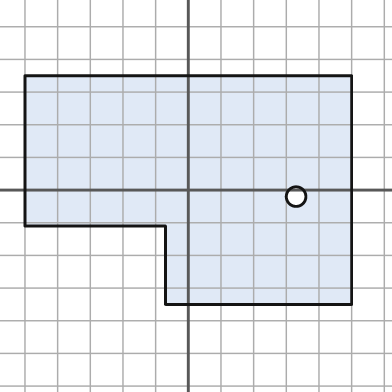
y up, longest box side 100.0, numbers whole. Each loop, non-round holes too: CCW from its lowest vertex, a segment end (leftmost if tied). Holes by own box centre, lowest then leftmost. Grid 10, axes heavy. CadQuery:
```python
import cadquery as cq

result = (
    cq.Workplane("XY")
    .moveTo(-7.0, -35.0)
    .lineTo(50.0, -35.0)
    .lineTo(50.0, 35.0)
    .lineTo(-50.0, 35.0)
    .lineTo(-50.0, -11.0)
    .lineTo(-7.0, -11.0)
    .close()
    .moveTo(33.0, -2.0)
    .circle(3.0)
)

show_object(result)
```